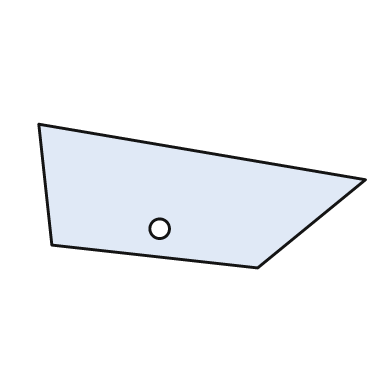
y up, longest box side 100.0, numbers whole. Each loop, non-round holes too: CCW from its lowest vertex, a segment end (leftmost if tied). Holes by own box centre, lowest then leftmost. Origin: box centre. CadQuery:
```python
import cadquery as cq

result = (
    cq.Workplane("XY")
    .moveTo(17.0, -22.0)
    .lineTo(50.0, 5.0)
    .lineTo(-50.0, 22.0)
    .lineTo(-46.0, -15.0)
    .close()
    .moveTo(-13.0, -10.0)
    .circle(3.0)
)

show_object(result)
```